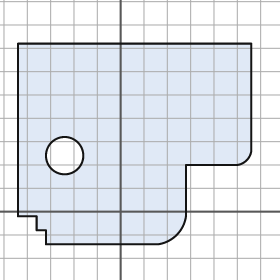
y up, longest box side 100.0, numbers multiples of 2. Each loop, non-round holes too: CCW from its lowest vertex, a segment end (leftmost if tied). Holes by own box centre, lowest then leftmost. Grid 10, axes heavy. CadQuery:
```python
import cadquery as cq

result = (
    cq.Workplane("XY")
    .moveTo(-32.0, -14.0)
    .lineTo(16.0, -14.0)
    .threePointArc((24.0, -10.0), (28.0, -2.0))
    .lineTo(28.0, 20.0)
    .lineTo(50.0, 20.0)
    .threePointArc((54.0, 22.0), (56.0, 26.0))
    .lineTo(56.0, 72.0)
    .lineTo(-44.0, 72.0)
    .lineTo(-44.0, -2.0)
    .lineTo(-36.0, -2.0)
    .lineTo(-36.0, -8.0)
    .lineTo(-32.0, -8.0)
    .close()
    .moveTo(-24.0, 24.0)
    .circle(8.0)
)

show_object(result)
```